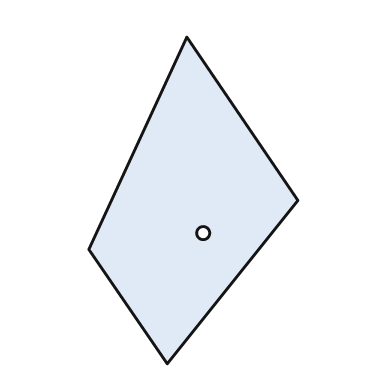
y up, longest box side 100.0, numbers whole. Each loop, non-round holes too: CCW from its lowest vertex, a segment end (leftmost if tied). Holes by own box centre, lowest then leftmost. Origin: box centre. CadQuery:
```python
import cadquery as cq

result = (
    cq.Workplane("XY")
    .moveTo(-8.0, -50.0)
    .lineTo(32.0, 0.0)
    .lineTo(-2.0, 50.0)
    .lineTo(-32.0, -15.0)
    .close()
    .moveTo(3.0, -10.0)
    .circle(2.0)
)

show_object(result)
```